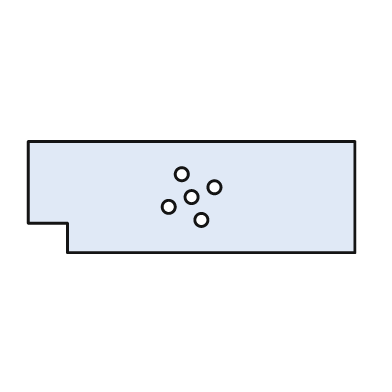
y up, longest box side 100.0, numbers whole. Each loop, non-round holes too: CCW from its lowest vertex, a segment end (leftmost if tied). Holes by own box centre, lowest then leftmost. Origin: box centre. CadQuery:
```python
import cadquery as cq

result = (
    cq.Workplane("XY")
    .moveTo(-38.0, -17.0)
    .lineTo(50.0, -17.0)
    .lineTo(50.0, 17.0)
    .lineTo(-50.0, 17.0)
    .lineTo(-50.0, -8.0)
    .lineTo(-38.0, -8.0)
    .close()
    .moveTo(3.0, -7.0)
    .circle(2.0)
    .moveTo(-7.0, -3.0)
    .circle(2.0)
    .moveTo(0.0, 0.0)
    .circle(2.0)
    .moveTo(7.0, 3.0)
    .circle(2.0)
    .moveTo(-3.0, 7.0)
    .circle(2.0)
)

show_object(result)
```